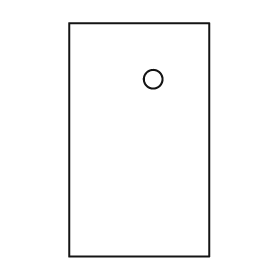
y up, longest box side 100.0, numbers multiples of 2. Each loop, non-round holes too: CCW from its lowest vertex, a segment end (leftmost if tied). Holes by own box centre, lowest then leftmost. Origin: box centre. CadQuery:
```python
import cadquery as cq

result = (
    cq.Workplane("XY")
    .moveTo(-30.0, -50.0)
    .lineTo(30.0, -50.0)
    .lineTo(30.0, 50.0)
    .lineTo(-30.0, 50.0)
    .close()
    .moveTo(6.0, 26.0)
    .circle(4.0)
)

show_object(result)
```